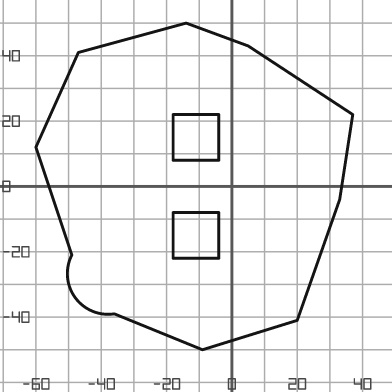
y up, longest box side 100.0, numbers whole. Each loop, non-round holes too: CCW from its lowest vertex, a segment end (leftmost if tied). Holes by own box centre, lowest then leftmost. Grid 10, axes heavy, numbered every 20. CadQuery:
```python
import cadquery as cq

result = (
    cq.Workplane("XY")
    .moveTo(-9.0, -50.0)
    .lineTo(20.0, -41.0)
    .lineTo(33.0, -4.0)
    .lineTo(37.0, 22.0)
    .lineTo(5.0, 43.0)
    .lineTo(-14.0, 50.0)
    .lineTo(-47.0, 41.0)
    .lineTo(-60.0, 12.0)
    .lineTo(-49.0, -21.0)
    .threePointArc((-48.0, -34.0), (-36.0, -39.0))
    .close()
    .moveTo(-18.0, -22.0)
    .lineTo(-4.0, -22.0)
    .lineTo(-4.0, -8.0)
    .lineTo(-18.0, -8.0)
    .close()
    .moveTo(-18.0, 8.0)
    .lineTo(-4.0, 8.0)
    .lineTo(-4.0, 22.0)
    .lineTo(-18.0, 22.0)
    .close()
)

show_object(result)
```